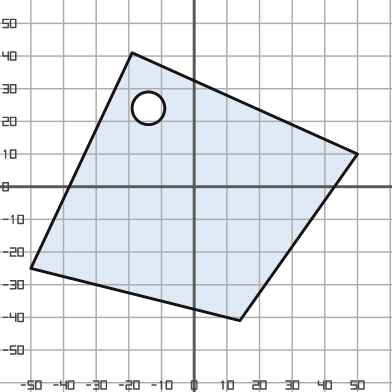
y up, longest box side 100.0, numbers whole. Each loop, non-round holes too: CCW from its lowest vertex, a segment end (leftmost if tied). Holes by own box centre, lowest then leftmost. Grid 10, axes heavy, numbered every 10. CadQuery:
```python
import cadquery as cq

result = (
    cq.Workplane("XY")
    .moveTo(14.0, -41.0)
    .lineTo(50.0, 10.0)
    .lineTo(-19.0, 41.0)
    .lineTo(-50.0, -25.0)
    .close()
    .moveTo(-14.0, 24.0)
    .circle(5.0)
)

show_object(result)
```